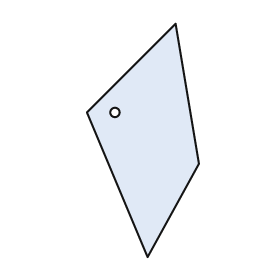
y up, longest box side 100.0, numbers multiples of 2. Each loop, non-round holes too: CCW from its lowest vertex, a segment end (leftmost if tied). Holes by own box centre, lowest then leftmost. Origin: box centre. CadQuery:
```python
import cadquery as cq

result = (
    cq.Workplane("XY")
    .moveTo(2.0, -50.0)
    .lineTo(24.0, -10.0)
    .lineTo(14.0, 50.0)
    .lineTo(-24.0, 12.0)
    .close()
    .moveTo(-12.0, 12.0)
    .circle(2.0)
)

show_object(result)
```